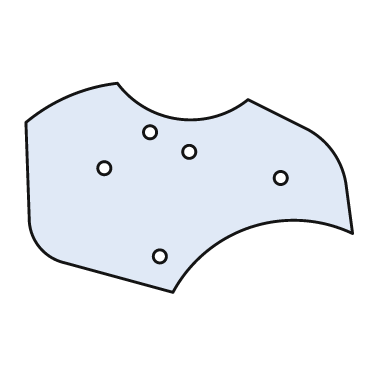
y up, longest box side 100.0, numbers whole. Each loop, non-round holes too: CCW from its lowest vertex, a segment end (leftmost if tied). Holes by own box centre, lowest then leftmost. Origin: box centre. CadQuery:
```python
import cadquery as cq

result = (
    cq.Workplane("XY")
    .moveTo(-5.0, -32.0)
    .threePointArc((19.0, -12.0), (50.0, -14.0))
    .lineTo(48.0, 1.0)
    .threePointArc((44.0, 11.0), (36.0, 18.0))
    .lineTo(18.0, 27.0)
    .threePointArc((-3.0, 21.0), (-22.0, 32.0))
    .threePointArc((-37.0, 28.0), (-50.0, 20.0))
    .lineTo(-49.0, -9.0)
    .threePointArc((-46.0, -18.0), (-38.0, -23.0))
    .close()
    .moveTo(-9.0, -21.0)
    .circle(2.0)
    .moveTo(28.0, 3.0)
    .circle(2.0)
    .moveTo(-26.0, 6.0)
    .circle(2.0)
    .moveTo(0.0, 11.0)
    .circle(2.0)
    .moveTo(-12.0, 17.0)
    .circle(2.0)
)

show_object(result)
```